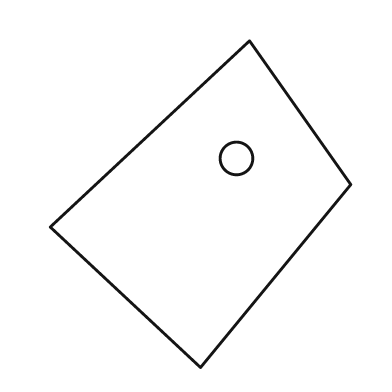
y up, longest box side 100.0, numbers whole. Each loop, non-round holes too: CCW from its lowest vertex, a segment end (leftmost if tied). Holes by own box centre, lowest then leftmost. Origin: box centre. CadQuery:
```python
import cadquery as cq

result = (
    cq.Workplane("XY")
    .moveTo(0.0, -50.0)
    .lineTo(46.0, 6.0)
    .lineTo(15.0, 50.0)
    .lineTo(-46.0, -7.0)
    .close()
    .moveTo(11.0, 14.0)
    .circle(5.0)
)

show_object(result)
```